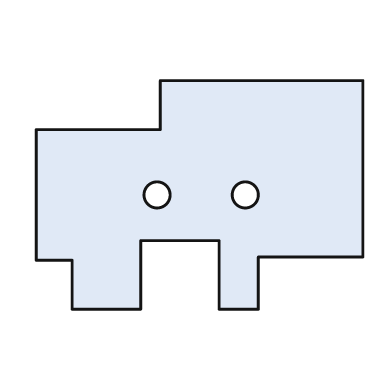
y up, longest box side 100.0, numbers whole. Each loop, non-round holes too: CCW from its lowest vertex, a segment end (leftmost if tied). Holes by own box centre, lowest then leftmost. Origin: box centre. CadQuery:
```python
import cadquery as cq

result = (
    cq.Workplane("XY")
    .moveTo(-39.0, -35.0)
    .lineTo(-18.0, -35.0)
    .lineTo(-18.0, -14.0)
    .lineTo(6.0, -14.0)
    .lineTo(6.0, -35.0)
    .lineTo(18.0, -35.0)
    .lineTo(18.0, -19.0)
    .lineTo(50.0, -19.0)
    .lineTo(50.0, 35.0)
    .lineTo(-12.0, 35.0)
    .lineTo(-12.0, 20.0)
    .lineTo(-50.0, 20.0)
    .lineTo(-50.0, -20.0)
    .lineTo(-39.0, -20.0)
    .close()
    .moveTo(-13.0, 0.0)
    .circle(4.0)
    .moveTo(14.0, 0.0)
    .circle(4.0)
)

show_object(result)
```